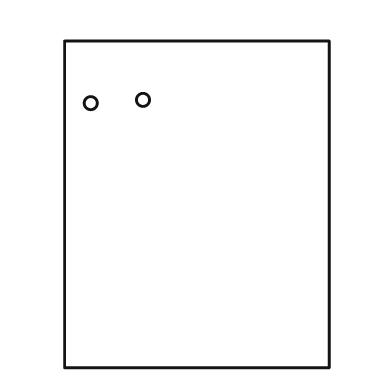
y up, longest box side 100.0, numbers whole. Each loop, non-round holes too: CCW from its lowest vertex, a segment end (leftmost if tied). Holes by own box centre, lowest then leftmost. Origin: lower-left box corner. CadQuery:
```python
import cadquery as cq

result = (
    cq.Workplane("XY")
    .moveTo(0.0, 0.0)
    .lineTo(81.0, 0.0)
    .lineTo(81.0, 100.0)
    .lineTo(0.0, 100.0)
    .close()
    .moveTo(8.0, 81.0)
    .circle(2.0)
    .moveTo(24.0, 82.0)
    .circle(2.0)
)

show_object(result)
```